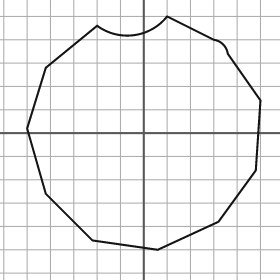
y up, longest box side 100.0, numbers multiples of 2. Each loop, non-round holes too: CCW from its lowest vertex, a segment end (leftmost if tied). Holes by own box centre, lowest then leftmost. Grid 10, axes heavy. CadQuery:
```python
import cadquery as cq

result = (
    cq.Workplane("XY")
    .moveTo(6.0, -50.0)
    .lineTo(32.0, -38.0)
    .lineTo(48.0, -16.0)
    .lineTo(50.0, 14.0)
    .lineTo(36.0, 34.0)
    .threePointArc((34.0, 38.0), (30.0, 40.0))
    .lineTo(10.0, 50.0)
    .threePointArc((-4.0, 42.0), (-20.0, 46.0))
    .lineTo(-42.0, 28.0)
    .lineTo(-50.0, 2.0)
    .lineTo(-42.0, -26.0)
    .lineTo(-22.0, -46.0)
    .close()
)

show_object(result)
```